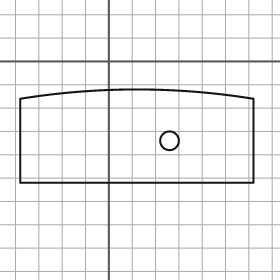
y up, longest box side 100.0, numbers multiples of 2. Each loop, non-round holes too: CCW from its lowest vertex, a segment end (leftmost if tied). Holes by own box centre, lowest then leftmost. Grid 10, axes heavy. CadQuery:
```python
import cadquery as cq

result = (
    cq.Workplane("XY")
    .moveTo(-38.0, -52.0)
    .lineTo(62.0, -52.0)
    .lineTo(62.0, -16.0)
    .threePointArc((12.0, -12.0), (-38.0, -16.0))
    .close()
    .moveTo(26.0, -34.0)
    .circle(4.0)
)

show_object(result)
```